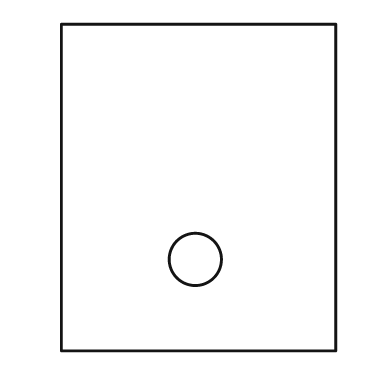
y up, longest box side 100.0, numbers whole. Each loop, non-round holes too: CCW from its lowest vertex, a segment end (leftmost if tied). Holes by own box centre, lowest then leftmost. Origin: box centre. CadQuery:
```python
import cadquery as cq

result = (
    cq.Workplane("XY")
    .moveTo(-42.0, -50.0)
    .lineTo(42.0, -50.0)
    .lineTo(42.0, 50.0)
    .lineTo(-42.0, 50.0)
    .close()
    .moveTo(-1.0, -22.0)
    .circle(8.0)
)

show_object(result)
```